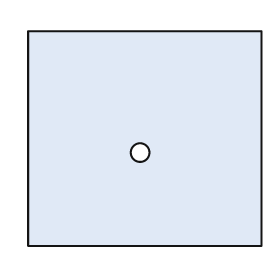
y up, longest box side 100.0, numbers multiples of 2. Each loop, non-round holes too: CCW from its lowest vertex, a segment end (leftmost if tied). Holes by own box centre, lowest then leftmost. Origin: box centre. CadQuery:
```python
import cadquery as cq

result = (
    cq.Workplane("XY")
    .moveTo(-50.0, -46.0)
    .lineTo(50.0, -46.0)
    .lineTo(50.0, 46.0)
    .lineTo(-50.0, 46.0)
    .close()
    .moveTo(-2.0, -6.0)
    .circle(4.0)
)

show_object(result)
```